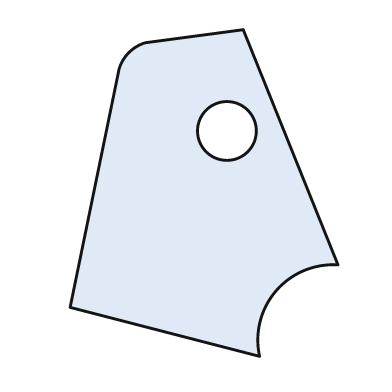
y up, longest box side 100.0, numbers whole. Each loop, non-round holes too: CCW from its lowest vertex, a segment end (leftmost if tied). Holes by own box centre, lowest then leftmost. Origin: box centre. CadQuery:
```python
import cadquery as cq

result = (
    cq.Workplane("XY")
    .moveTo(17.0, -50.0)
    .threePointArc((22.0, -30.0), (41.0, -22.0))
    .lineTo(12.0, 50.0)
    .lineTo(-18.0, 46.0)
    .threePointArc((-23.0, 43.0), (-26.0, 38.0))
    .lineTo(-41.0, -35.0)
    .close()
    .moveTo(7.0, 19.0)
    .circle(9.0)
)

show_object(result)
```